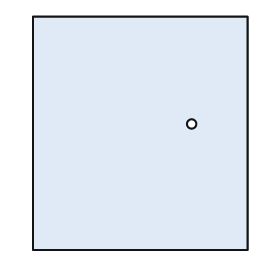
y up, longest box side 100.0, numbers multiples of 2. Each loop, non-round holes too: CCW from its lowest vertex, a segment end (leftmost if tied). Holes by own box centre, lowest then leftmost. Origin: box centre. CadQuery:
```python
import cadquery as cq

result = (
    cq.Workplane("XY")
    .moveTo(-46.0, -50.0)
    .lineTo(46.0, -50.0)
    .lineTo(46.0, 50.0)
    .lineTo(-46.0, 50.0)
    .close()
    .moveTo(22.0, 4.0)
    .circle(2.0)
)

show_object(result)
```